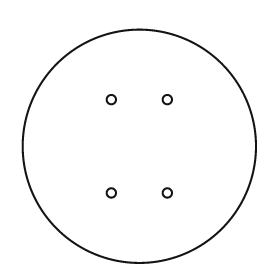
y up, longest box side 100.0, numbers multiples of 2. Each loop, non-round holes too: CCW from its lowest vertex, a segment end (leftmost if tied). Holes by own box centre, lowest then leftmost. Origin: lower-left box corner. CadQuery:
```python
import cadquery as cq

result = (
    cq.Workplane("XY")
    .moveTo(50.0, 50.0)
    .circle(50.0)
    .moveTo(38.0, 30.0)
    .circle(2.0)
    .moveTo(62.0, 30.0)
    .circle(2.0)
    .moveTo(38.0, 70.0)
    .circle(2.0)
    .moveTo(62.0, 70.0)
    .circle(2.0)
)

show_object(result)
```